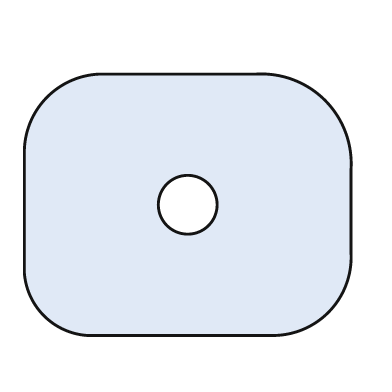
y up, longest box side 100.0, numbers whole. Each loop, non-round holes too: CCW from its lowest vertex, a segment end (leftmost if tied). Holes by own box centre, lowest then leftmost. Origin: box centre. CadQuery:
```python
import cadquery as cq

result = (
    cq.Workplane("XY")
    .moveTo(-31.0, -40.0)
    .lineTo(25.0, -40.0)
    .threePointArc((43.0, -33.0), (50.0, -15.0))
    .lineTo(50.0, 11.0)
    .threePointArc((42.0, 32.0), (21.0, 40.0))
    .lineTo(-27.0, 40.0)
    .threePointArc((-43.0, 33.0), (-50.0, 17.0))
    .lineTo(-50.0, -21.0)
    .threePointArc((-44.0, -34.0), (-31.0, -40.0))
    .close()
    .moveTo(0.0, 0.0)
    .circle(9.0)
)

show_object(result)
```